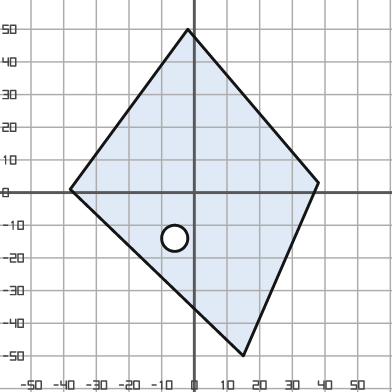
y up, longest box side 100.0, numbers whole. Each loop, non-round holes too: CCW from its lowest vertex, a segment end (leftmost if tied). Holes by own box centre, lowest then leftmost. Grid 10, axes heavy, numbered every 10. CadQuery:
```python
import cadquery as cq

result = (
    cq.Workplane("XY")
    .moveTo(15.0, -50.0)
    .lineTo(38.0, 3.0)
    .lineTo(-2.0, 50.0)
    .lineTo(-38.0, 1.0)
    .close()
    .moveTo(-6.0, -14.0)
    .circle(4.0)
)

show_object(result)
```